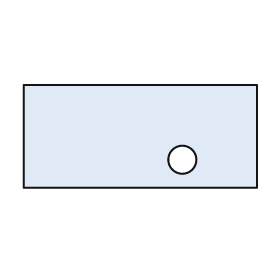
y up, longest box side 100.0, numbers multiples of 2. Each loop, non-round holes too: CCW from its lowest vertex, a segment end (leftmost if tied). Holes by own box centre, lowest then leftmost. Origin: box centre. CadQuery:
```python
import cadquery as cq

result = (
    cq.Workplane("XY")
    .moveTo(-50.0, -22.0)
    .lineTo(50.0, -22.0)
    .lineTo(50.0, 22.0)
    .lineTo(-50.0, 22.0)
    .close()
    .moveTo(18.0, -10.0)
    .circle(6.0)
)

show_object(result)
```